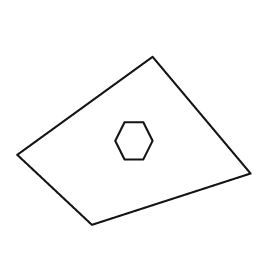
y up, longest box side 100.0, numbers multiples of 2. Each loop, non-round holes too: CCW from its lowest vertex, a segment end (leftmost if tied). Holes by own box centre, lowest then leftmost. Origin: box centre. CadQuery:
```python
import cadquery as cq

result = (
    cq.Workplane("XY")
    .moveTo(-18.0, -36.0)
    .lineTo(50.0, -14.0)
    .lineTo(8.0, 36.0)
    .lineTo(-50.0, -6.0)
    .close()
    .moveTo(-4.0, -8.0)
    .lineTo(4.0, -8.0)
    .lineTo(8.0, 0.0)
    .lineTo(4.0, 8.0)
    .lineTo(-4.0, 8.0)
    .lineTo(-8.0, 0.0)
    .close()
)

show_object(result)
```